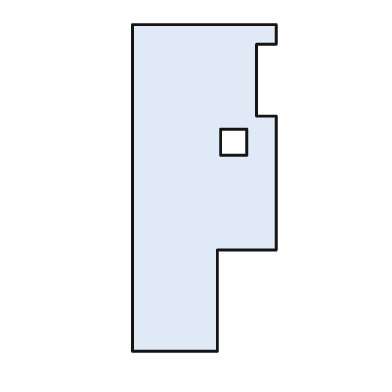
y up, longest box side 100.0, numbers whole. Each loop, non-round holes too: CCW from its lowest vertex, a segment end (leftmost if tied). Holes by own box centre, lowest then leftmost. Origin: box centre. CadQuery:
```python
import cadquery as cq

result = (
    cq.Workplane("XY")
    .moveTo(-22.0, -50.0)
    .lineTo(4.0, -50.0)
    .lineTo(4.0, -19.0)
    .lineTo(22.0, -19.0)
    .lineTo(22.0, 22.0)
    .lineTo(16.0, 22.0)
    .lineTo(16.0, 44.0)
    .lineTo(22.0, 44.0)
    .lineTo(22.0, 50.0)
    .lineTo(-22.0, 50.0)
    .close()
    .moveTo(5.0, 10.0)
    .lineTo(13.0, 10.0)
    .lineTo(13.0, 18.0)
    .lineTo(5.0, 18.0)
    .close()
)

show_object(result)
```